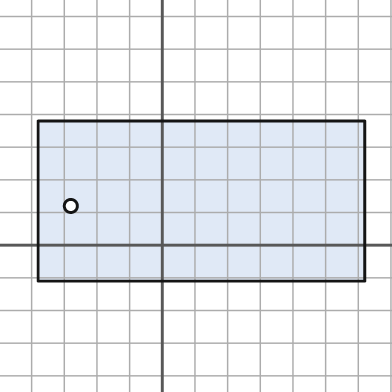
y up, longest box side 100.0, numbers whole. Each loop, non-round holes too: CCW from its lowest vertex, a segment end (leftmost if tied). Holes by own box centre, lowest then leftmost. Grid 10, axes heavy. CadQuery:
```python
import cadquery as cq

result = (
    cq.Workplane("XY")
    .moveTo(-38.0, -11.0)
    .lineTo(62.0, -11.0)
    .lineTo(62.0, 38.0)
    .lineTo(-38.0, 38.0)
    .close()
    .moveTo(-28.0, 12.0)
    .circle(2.0)
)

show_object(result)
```